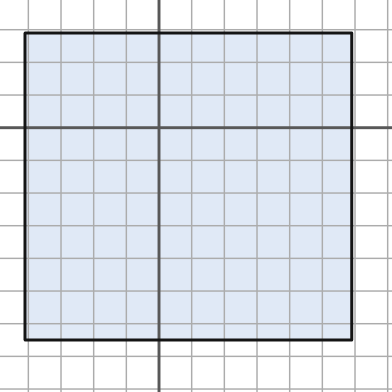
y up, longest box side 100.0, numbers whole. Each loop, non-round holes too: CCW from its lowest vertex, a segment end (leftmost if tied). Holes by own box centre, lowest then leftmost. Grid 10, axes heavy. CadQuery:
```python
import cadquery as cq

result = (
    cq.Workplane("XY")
    .moveTo(-41.0, -65.0)
    .lineTo(59.0, -65.0)
    .lineTo(59.0, 29.0)
    .lineTo(-41.0, 29.0)
    .close()
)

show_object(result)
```